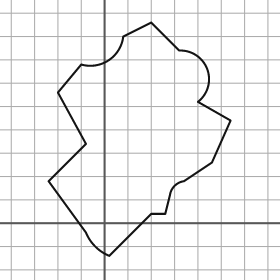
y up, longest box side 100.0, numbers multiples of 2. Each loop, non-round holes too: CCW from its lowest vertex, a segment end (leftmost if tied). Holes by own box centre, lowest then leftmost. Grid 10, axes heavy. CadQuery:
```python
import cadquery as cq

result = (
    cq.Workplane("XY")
    .moveTo(2.0, -14.0)
    .lineTo(20.0, 4.0)
    .lineTo(26.0, 4.0)
    .lineTo(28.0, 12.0)
    .threePointArc((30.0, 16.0), (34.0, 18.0))
    .lineTo(46.0, 26.0)
    .lineTo(54.0, 44.0)
    .lineTo(40.0, 52.0)
    .threePointArc((44.0, 66.0), (32.0, 74.0))
    .lineTo(20.0, 86.0)
    .lineTo(8.0, 80.0)
    .threePointArc((2.0, 70.0), (-10.0, 68.0))
    .lineTo(-20.0, 56.0)
    .lineTo(-8.0, 34.0)
    .lineTo(-24.0, 18.0)
    .lineTo(-8.0, -4.0)
    .threePointArc((-4.0, -10.0), (2.0, -14.0))
    .close()
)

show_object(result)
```